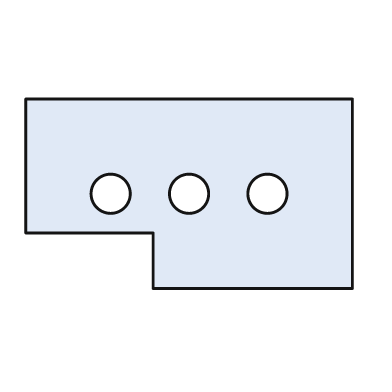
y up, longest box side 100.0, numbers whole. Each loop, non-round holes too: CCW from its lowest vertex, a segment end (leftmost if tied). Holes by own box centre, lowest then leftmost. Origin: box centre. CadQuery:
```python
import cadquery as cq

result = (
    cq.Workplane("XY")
    .moveTo(-11.0, -29.0)
    .lineTo(50.0, -29.0)
    .lineTo(50.0, 29.0)
    .lineTo(-50.0, 29.0)
    .lineTo(-50.0, -12.0)
    .lineTo(-11.0, -12.0)
    .close()
    .moveTo(-24.0, 0.0)
    .circle(6.0)
    .moveTo(0.0, 0.0)
    .circle(6.0)
    .moveTo(24.0, 0.0)
    .circle(6.0)
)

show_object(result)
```